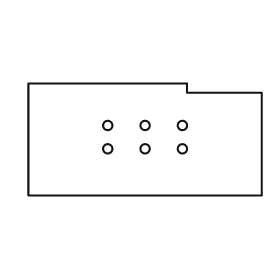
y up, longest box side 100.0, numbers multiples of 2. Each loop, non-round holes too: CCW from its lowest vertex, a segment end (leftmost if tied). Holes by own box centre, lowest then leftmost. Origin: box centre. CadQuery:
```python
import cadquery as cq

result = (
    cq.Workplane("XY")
    .moveTo(-50.0, -24.0)
    .lineTo(50.0, -24.0)
    .lineTo(50.0, 20.0)
    .lineTo(18.0, 20.0)
    .lineTo(18.0, 24.0)
    .lineTo(-50.0, 24.0)
    .close()
    .moveTo(-16.0, -4.0)
    .circle(2.0)
    .moveTo(0.0, -4.0)
    .circle(2.0)
    .moveTo(16.0, -4.0)
    .circle(2.0)
    .moveTo(-16.0, 6.0)
    .circle(2.0)
    .moveTo(0.0, 6.0)
    .circle(2.0)
    .moveTo(16.0, 6.0)
    .circle(2.0)
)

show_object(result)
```